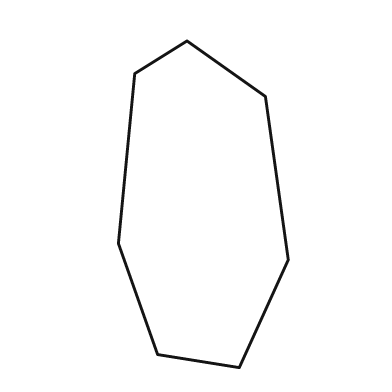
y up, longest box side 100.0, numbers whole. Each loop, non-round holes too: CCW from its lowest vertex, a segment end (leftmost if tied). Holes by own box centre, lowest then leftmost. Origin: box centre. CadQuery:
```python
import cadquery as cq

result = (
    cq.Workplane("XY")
    .moveTo(11.0, -50.0)
    .lineTo(26.0, -17.0)
    .lineTo(19.0, 33.0)
    .lineTo(-5.0, 50.0)
    .lineTo(-21.0, 40.0)
    .lineTo(-26.0, -12.0)
    .lineTo(-14.0, -46.0)
    .close()
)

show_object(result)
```